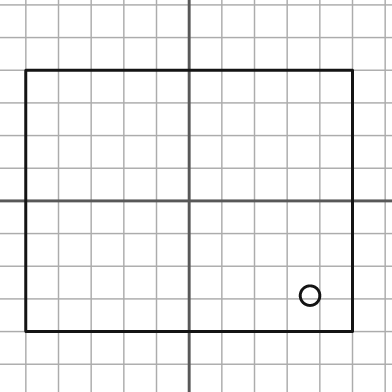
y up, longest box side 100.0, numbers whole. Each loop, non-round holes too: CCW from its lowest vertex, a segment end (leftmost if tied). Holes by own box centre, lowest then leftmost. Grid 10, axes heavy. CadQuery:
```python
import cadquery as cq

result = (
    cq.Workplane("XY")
    .moveTo(-50.0, -40.0)
    .lineTo(50.0, -40.0)
    .lineTo(50.0, 40.0)
    .lineTo(-50.0, 40.0)
    .close()
    .moveTo(37.0, -29.0)
    .circle(3.0)
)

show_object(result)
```